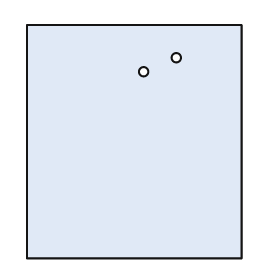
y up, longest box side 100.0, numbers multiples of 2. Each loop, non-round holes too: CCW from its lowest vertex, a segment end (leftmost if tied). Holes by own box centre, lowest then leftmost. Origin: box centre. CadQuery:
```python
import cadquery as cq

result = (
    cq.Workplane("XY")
    .moveTo(-46.0, -50.0)
    .lineTo(46.0, -50.0)
    .lineTo(46.0, 50.0)
    .lineTo(-46.0, 50.0)
    .close()
    .moveTo(4.0, 30.0)
    .circle(2.0)
    .moveTo(18.0, 36.0)
    .circle(2.0)
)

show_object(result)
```